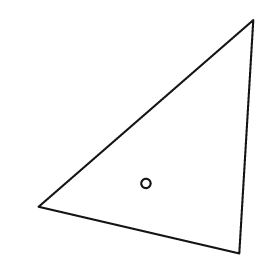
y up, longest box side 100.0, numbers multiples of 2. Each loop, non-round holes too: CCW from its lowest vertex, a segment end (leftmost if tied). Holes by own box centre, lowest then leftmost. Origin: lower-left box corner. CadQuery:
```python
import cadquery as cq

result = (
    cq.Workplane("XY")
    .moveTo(86.0, 0.0)
    .lineTo(92.0, 100.0)
    .lineTo(0.0, 20.0)
    .close()
    .moveTo(46.0, 30.0)
    .circle(2.0)
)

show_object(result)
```